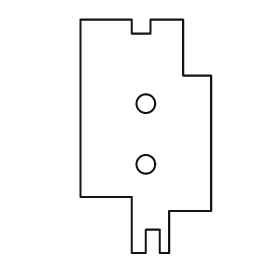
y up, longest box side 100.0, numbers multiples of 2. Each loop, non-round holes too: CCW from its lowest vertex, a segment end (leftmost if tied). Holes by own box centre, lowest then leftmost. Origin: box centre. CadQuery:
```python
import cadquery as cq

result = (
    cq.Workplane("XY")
    .moveTo(-6.0, -50.0)
    .lineTo(0.0, -50.0)
    .lineTo(0.0, -40.0)
    .lineTo(6.0, -40.0)
    .lineTo(6.0, -50.0)
    .lineTo(10.0, -50.0)
    .lineTo(10.0, -32.0)
    .lineTo(28.0, -32.0)
    .lineTo(28.0, 26.0)
    .lineTo(16.0, 26.0)
    .lineTo(16.0, 50.0)
    .lineTo(2.0, 50.0)
    .lineTo(2.0, 44.0)
    .lineTo(-6.0, 44.0)
    .lineTo(-6.0, 50.0)
    .lineTo(-28.0, 50.0)
    .lineTo(-28.0, -26.0)
    .lineTo(-6.0, -26.0)
    .close()
    .moveTo(0.0, -12.0)
    .circle(4.0)
    .moveTo(0.0, 14.0)
    .circle(4.0)
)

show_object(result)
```